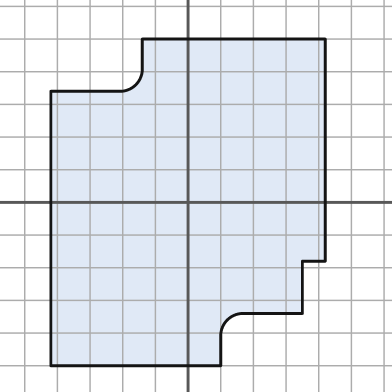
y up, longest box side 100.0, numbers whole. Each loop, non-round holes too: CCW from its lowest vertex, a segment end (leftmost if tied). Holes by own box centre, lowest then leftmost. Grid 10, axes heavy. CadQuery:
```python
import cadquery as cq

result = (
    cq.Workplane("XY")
    .moveTo(-42.0, -50.0)
    .lineTo(10.0, -50.0)
    .lineTo(10.0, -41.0)
    .threePointArc((12.0, -36.0), (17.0, -34.0))
    .lineTo(35.0, -34.0)
    .lineTo(35.0, -18.0)
    .lineTo(42.0, -18.0)
    .lineTo(42.0, 50.0)
    .lineTo(-14.0, 50.0)
    .lineTo(-14.0, 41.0)
    .threePointArc((-16.0, 36.0), (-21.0, 34.0))
    .lineTo(-42.0, 34.0)
    .close()
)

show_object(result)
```